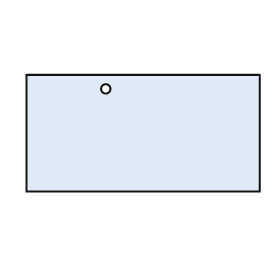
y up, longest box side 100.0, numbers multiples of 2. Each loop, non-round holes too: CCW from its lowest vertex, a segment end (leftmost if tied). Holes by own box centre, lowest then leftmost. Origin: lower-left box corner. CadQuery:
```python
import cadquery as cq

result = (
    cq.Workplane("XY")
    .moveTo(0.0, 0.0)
    .lineTo(100.0, 0.0)
    .lineTo(100.0, 50.0)
    .lineTo(0.0, 50.0)
    .close()
    .moveTo(34.0, 44.0)
    .circle(2.0)
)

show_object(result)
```